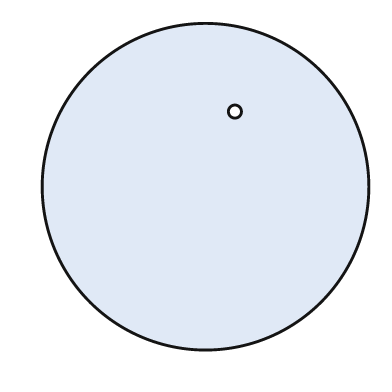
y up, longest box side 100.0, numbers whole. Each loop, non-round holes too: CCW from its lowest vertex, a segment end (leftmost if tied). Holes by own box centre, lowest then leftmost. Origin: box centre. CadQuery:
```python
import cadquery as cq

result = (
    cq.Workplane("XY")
    .moveTo(0.0, 0.0)
    .circle(50.0)
    .moveTo(9.0, 23.0)
    .circle(2.0)
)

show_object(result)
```